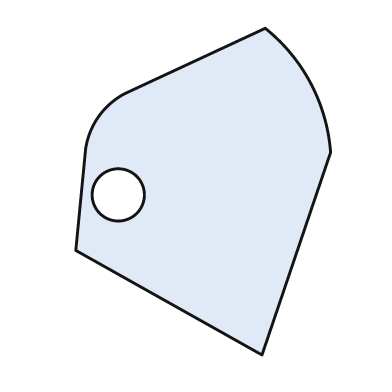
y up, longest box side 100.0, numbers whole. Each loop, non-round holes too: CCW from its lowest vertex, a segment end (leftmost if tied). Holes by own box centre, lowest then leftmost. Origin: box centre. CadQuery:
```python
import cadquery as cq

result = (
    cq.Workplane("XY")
    .moveTo(18.0, -50.0)
    .lineTo(39.0, 12.0)
    .threePointArc((33.0, 33.0), (19.0, 50.0))
    .lineTo(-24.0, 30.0)
    .threePointArc((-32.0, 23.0), (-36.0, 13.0))
    .lineTo(-39.0, -18.0)
    .close()
    .moveTo(-26.0, -1.0)
    .circle(8.0)
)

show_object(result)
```